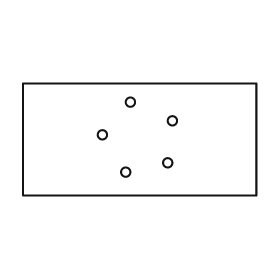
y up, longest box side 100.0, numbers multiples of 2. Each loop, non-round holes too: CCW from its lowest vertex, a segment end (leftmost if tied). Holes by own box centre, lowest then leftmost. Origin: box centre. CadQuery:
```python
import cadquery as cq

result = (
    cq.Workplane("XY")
    .moveTo(-50.0, -24.0)
    .lineTo(50.0, -24.0)
    .lineTo(50.0, 24.0)
    .lineTo(-50.0, 24.0)
    .close()
    .moveTo(-6.0, -14.0)
    .circle(2.0)
    .moveTo(12.0, -10.0)
    .circle(2.0)
    .moveTo(-16.0, 2.0)
    .circle(2.0)
    .moveTo(14.0, 8.0)
    .circle(2.0)
    .moveTo(-4.0, 16.0)
    .circle(2.0)
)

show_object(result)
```